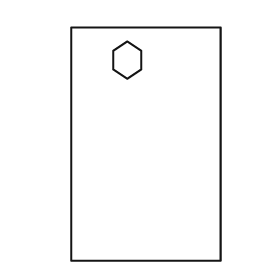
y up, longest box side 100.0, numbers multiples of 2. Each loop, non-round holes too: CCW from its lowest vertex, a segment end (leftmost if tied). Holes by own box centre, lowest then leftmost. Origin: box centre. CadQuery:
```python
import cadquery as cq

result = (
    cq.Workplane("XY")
    .moveTo(-32.0, -50.0)
    .lineTo(32.0, -50.0)
    .lineTo(32.0, 50.0)
    .lineTo(-32.0, 50.0)
    .close()
    .moveTo(-8.0, 28.0)
    .lineTo(-2.0, 32.0)
    .lineTo(-2.0, 40.0)
    .lineTo(-8.0, 44.0)
    .lineTo(-14.0, 40.0)
    .lineTo(-14.0, 32.0)
    .close()
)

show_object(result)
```